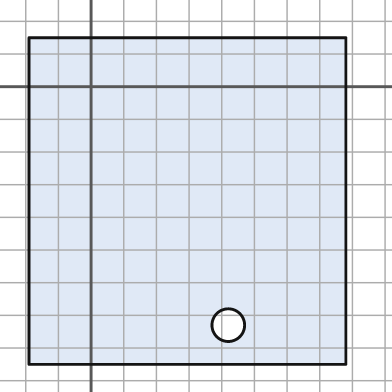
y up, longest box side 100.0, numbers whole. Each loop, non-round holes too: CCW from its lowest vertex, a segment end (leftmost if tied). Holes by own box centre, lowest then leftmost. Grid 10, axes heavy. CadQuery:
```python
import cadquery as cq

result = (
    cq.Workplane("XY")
    .moveTo(-19.0, -85.0)
    .lineTo(78.0, -85.0)
    .lineTo(78.0, 15.0)
    .lineTo(-19.0, 15.0)
    .close()
    .moveTo(42.0, -73.0)
    .circle(5.0)
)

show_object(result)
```